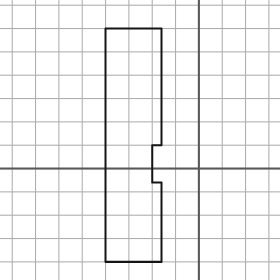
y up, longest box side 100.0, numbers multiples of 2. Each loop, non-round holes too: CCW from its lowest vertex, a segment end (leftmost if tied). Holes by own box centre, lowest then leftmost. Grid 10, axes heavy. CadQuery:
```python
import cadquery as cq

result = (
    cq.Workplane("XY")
    .moveTo(-40.0, -40.0)
    .lineTo(-16.0, -40.0)
    .lineTo(-16.0, -6.0)
    .lineTo(-20.0, -6.0)
    .lineTo(-20.0, 10.0)
    .lineTo(-16.0, 10.0)
    .lineTo(-16.0, 60.0)
    .lineTo(-40.0, 60.0)
    .close()
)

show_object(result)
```